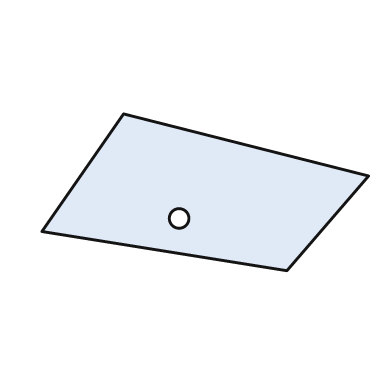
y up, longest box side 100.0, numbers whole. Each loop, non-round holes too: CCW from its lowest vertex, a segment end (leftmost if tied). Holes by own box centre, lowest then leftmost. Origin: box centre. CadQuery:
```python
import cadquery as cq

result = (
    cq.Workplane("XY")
    .moveTo(25.0, -24.0)
    .lineTo(50.0, 5.0)
    .lineTo(-25.0, 24.0)
    .lineTo(-50.0, -12.0)
    .close()
    .moveTo(-8.0, -8.0)
    .circle(3.0)
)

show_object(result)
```